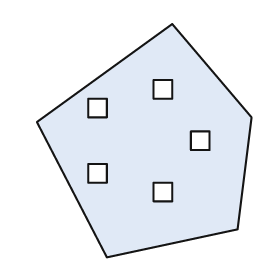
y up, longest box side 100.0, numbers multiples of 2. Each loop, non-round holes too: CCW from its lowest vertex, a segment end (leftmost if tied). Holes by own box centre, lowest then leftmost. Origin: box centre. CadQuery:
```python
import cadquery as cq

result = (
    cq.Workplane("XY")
    .moveTo(-16.0, -50.0)
    .lineTo(40.0, -38.0)
    .lineTo(46.0, 10.0)
    .lineTo(12.0, 50.0)
    .lineTo(-46.0, 8.0)
    .close()
    .moveTo(4.0, -26.0)
    .lineTo(12.0, -26.0)
    .lineTo(12.0, -18.0)
    .lineTo(4.0, -18.0)
    .close()
    .moveTo(-24.0, -18.0)
    .lineTo(-16.0, -18.0)
    .lineTo(-16.0, -10.0)
    .lineTo(-24.0, -10.0)
    .close()
    .moveTo(20.0, -4.0)
    .lineTo(28.0, -4.0)
    .lineTo(28.0, 4.0)
    .lineTo(20.0, 4.0)
    .close()
    .moveTo(-24.0, 10.0)
    .lineTo(-16.0, 10.0)
    .lineTo(-16.0, 18.0)
    .lineTo(-24.0, 18.0)
    .close()
    .moveTo(4.0, 18.0)
    .lineTo(12.0, 18.0)
    .lineTo(12.0, 26.0)
    .lineTo(4.0, 26.0)
    .close()
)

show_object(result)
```